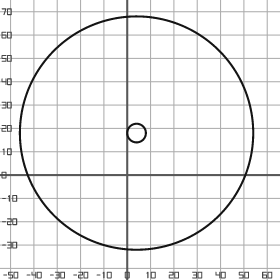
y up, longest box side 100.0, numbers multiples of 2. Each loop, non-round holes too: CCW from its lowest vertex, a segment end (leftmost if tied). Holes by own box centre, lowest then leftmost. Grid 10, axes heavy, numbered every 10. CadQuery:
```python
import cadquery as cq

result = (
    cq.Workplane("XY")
    .moveTo(4.0, 18.0)
    .circle(50.0)
    .moveTo(4.0, 18.0)
    .circle(4.0)
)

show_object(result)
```